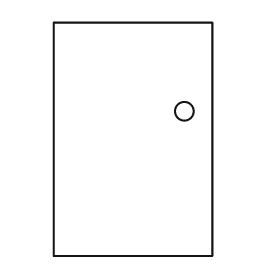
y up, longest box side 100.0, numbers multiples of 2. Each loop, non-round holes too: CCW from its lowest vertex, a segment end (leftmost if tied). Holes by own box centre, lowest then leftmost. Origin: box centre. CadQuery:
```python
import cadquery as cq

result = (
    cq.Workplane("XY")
    .moveTo(-34.0, -50.0)
    .lineTo(34.0, -50.0)
    .lineTo(34.0, 50.0)
    .lineTo(-34.0, 50.0)
    .close()
    .moveTo(22.0, 12.0)
    .circle(4.0)
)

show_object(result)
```